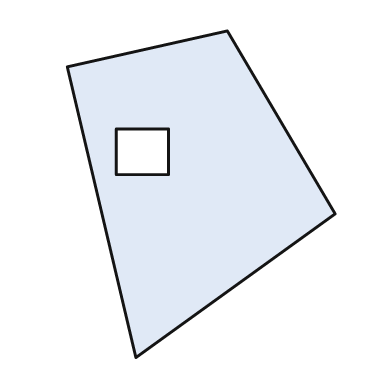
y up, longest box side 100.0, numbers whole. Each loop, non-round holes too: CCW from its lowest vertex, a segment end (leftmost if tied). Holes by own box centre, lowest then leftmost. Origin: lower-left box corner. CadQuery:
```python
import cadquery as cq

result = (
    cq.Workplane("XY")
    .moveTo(21.0, 0.0)
    .lineTo(82.0, 44.0)
    .lineTo(49.0, 100.0)
    .lineTo(0.0, 89.0)
    .close()
    .moveTo(15.0, 56.0)
    .lineTo(31.0, 56.0)
    .lineTo(31.0, 70.0)
    .lineTo(15.0, 70.0)
    .close()
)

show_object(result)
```